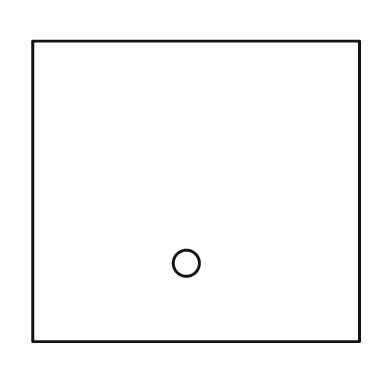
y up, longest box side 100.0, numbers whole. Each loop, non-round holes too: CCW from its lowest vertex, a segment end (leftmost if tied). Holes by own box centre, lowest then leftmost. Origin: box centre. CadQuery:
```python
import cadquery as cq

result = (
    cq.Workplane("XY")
    .moveTo(-50.0, -46.0)
    .lineTo(50.0, -46.0)
    .lineTo(50.0, 46.0)
    .lineTo(-50.0, 46.0)
    .close()
    .moveTo(-3.0, -22.0)
    .circle(4.0)
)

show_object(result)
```